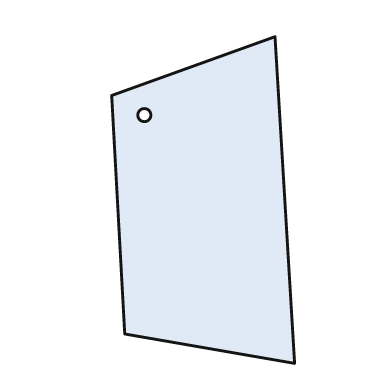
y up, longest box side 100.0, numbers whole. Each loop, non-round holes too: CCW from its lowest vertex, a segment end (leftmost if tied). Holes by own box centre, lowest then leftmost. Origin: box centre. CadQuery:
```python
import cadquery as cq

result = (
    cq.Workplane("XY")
    .moveTo(28.0, -50.0)
    .lineTo(22.0, 50.0)
    .lineTo(-28.0, 32.0)
    .lineTo(-24.0, -41.0)
    .close()
    .moveTo(-18.0, 26.0)
    .circle(2.0)
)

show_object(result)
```